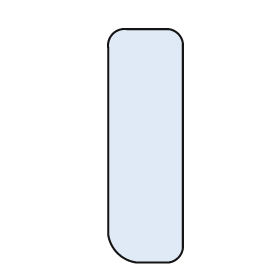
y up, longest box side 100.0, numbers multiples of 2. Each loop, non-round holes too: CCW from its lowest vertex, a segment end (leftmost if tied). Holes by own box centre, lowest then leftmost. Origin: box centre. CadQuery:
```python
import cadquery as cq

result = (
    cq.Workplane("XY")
    .moveTo(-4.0, -50.0)
    .lineTo(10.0, -50.0)
    .threePointArc((14.0, -48.0), (16.0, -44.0))
    .lineTo(16.0, 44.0)
    .threePointArc((14.0, 48.0), (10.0, 50.0))
    .lineTo(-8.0, 50.0)
    .threePointArc((-14.0, 48.0), (-16.0, 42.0))
    .lineTo(-16.0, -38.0)
    .threePointArc((-12.0, -46.0), (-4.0, -50.0))
    .close()
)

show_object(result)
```